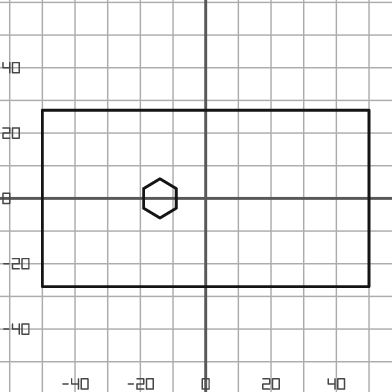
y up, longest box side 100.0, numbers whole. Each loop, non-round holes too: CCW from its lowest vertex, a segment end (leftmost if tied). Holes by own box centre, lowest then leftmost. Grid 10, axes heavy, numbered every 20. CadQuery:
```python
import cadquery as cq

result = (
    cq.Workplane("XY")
    .moveTo(-50.0, -27.0)
    .lineTo(50.0, -27.0)
    .lineTo(50.0, 27.0)
    .lineTo(-50.0, 27.0)
    .close()
    .moveTo(-14.0, -6.0)
    .lineTo(-9.0, -3.0)
    .lineTo(-9.0, 3.0)
    .lineTo(-14.0, 6.0)
    .lineTo(-19.0, 3.0)
    .lineTo(-19.0, -3.0)
    .close()
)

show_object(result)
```